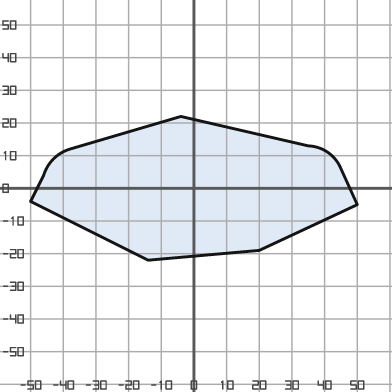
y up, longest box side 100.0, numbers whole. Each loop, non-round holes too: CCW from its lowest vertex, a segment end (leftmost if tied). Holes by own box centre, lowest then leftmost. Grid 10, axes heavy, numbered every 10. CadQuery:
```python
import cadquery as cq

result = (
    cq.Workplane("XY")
    .moveTo(-14.0, -22.0)
    .lineTo(20.0, -19.0)
    .lineTo(50.0, -5.0)
    .lineTo(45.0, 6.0)
    .threePointArc((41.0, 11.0), (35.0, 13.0))
    .lineTo(-4.0, 22.0)
    .lineTo(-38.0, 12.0)
    .threePointArc((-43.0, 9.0), (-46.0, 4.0))
    .lineTo(-50.0, -4.0)
    .close()
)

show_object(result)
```